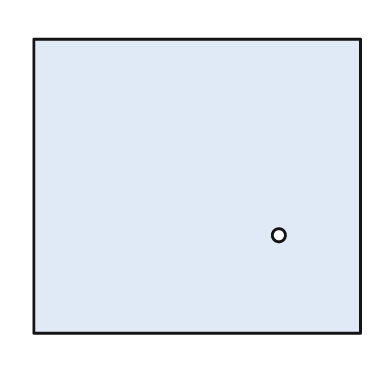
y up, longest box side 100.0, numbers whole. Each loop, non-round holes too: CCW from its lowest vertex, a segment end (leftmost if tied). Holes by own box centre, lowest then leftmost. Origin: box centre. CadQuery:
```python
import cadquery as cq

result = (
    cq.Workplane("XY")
    .moveTo(-50.0, -45.0)
    .lineTo(50.0, -45.0)
    .lineTo(50.0, 45.0)
    .lineTo(-50.0, 45.0)
    .close()
    .moveTo(25.0, -15.0)
    .circle(2.0)
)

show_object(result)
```